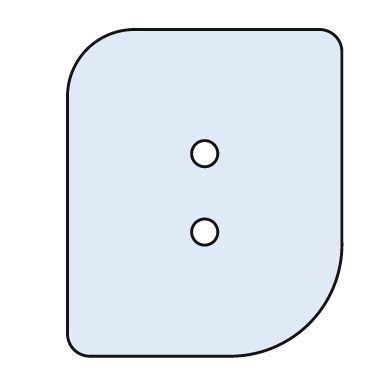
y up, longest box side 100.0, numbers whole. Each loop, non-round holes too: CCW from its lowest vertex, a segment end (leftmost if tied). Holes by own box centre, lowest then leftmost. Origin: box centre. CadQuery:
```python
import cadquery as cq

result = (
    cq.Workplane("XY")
    .moveTo(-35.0, -50.0)
    .lineTo(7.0, -50.0)
    .threePointArc((32.0, -40.0), (42.0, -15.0))
    .lineTo(42.0, 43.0)
    .threePointArc((40.0, 48.0), (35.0, 50.0))
    .lineTo(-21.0, 50.0)
    .threePointArc((-36.0, 44.0), (-42.0, 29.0))
    .lineTo(-42.0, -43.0)
    .threePointArc((-40.0, -48.0), (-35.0, -50.0))
    .close()
    .moveTo(0.0, -12.0)
    .circle(4.0)
    .moveTo(0.0, 12.0)
    .circle(4.0)
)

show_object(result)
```